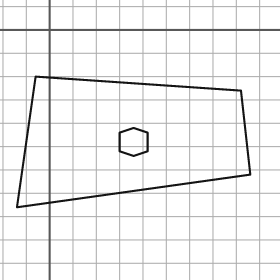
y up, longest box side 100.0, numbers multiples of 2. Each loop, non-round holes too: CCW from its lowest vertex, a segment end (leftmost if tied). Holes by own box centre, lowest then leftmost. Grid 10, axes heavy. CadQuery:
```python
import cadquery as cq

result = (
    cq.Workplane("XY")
    .moveTo(-14.0, -76.0)
    .lineTo(86.0, -62.0)
    .lineTo(82.0, -26.0)
    .lineTo(-6.0, -20.0)
    .close()
    .moveTo(36.0, -54.0)
    .lineTo(42.0, -52.0)
    .lineTo(42.0, -44.0)
    .lineTo(36.0, -42.0)
    .lineTo(30.0, -44.0)
    .lineTo(30.0, -52.0)
    .close()
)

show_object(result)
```